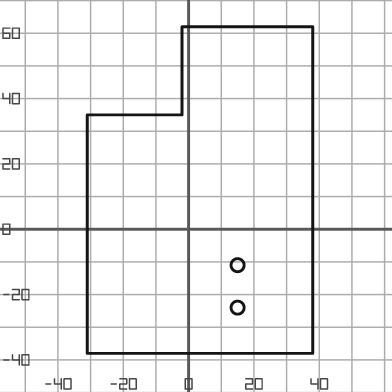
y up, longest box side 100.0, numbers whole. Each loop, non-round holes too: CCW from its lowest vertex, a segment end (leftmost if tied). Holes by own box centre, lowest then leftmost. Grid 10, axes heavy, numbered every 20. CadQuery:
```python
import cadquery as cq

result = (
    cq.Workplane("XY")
    .moveTo(-31.0, -38.0)
    .lineTo(38.0, -38.0)
    .lineTo(38.0, 62.0)
    .lineTo(-2.0, 62.0)
    .lineTo(-2.0, 35.0)
    .lineTo(-31.0, 35.0)
    .close()
    .moveTo(15.0, -24.0)
    .circle(2.0)
    .moveTo(15.0, -11.0)
    .circle(2.0)
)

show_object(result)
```